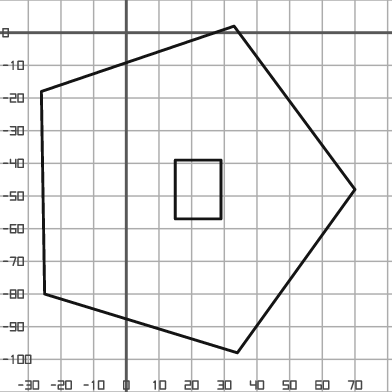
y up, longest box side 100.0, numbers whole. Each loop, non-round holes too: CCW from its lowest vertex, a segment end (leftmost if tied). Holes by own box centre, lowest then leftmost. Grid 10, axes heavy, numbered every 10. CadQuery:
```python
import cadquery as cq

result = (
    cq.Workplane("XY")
    .moveTo(34.0, -98.0)
    .lineTo(70.0, -48.0)
    .lineTo(33.0, 2.0)
    .lineTo(-26.0, -18.0)
    .lineTo(-25.0, -80.0)
    .close()
    .moveTo(15.0, -57.0)
    .lineTo(29.0, -57.0)
    .lineTo(29.0, -39.0)
    .lineTo(15.0, -39.0)
    .close()
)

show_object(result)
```